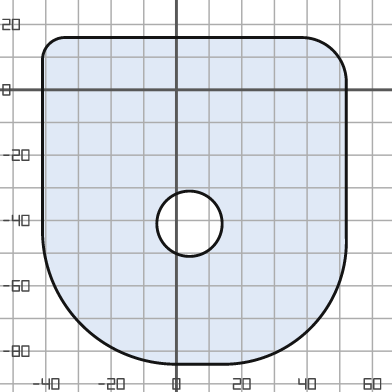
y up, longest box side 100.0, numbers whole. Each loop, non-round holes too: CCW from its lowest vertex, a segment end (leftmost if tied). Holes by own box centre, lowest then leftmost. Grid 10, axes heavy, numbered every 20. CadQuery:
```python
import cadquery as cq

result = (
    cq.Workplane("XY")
    .moveTo(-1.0, -84.0)
    .lineTo(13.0, -84.0)
    .threePointArc((41.0, -73.0), (52.0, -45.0))
    .lineTo(52.0, 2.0)
    .threePointArc((48.0, 12.0), (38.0, 16.0))
    .lineTo(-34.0, 16.0)
    .threePointArc((-39.0, 14.0), (-41.0, 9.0))
    .lineTo(-41.0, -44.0)
    .threePointArc((-29.0, -72.0), (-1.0, -84.0))
    .close()
    .moveTo(4.0, -41.0)
    .circle(10.0)
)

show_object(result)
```